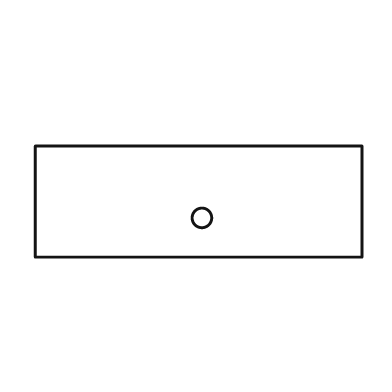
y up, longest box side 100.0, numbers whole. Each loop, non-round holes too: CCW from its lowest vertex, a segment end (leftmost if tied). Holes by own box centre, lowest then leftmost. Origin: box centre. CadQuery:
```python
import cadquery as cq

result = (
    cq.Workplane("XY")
    .moveTo(-50.0, -17.0)
    .lineTo(50.0, -17.0)
    .lineTo(50.0, 17.0)
    .lineTo(-50.0, 17.0)
    .close()
    .moveTo(1.0, -5.0)
    .circle(3.0)
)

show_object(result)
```